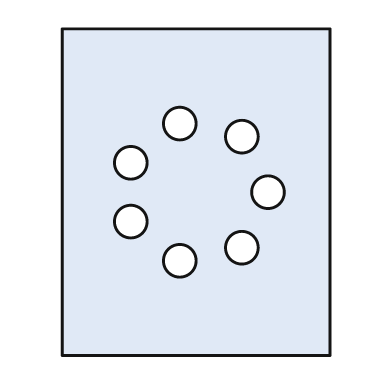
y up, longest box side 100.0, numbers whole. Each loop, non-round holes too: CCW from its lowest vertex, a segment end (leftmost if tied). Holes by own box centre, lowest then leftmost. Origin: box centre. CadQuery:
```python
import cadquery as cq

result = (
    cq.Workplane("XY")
    .moveTo(-41.0, -50.0)
    .lineTo(41.0, -50.0)
    .lineTo(41.0, 50.0)
    .lineTo(-41.0, 50.0)
    .close()
    .moveTo(-5.0, -21.0)
    .circle(5.0)
    .moveTo(14.0, -17.0)
    .circle(5.0)
    .moveTo(-20.0, -9.0)
    .circle(5.0)
    .moveTo(22.0, 0.0)
    .circle(5.0)
    .moveTo(-20.0, 9.0)
    .circle(5.0)
    .moveTo(14.0, 17.0)
    .circle(5.0)
    .moveTo(-5.0, 21.0)
    .circle(5.0)
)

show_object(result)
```